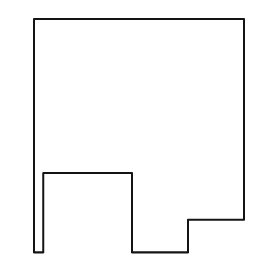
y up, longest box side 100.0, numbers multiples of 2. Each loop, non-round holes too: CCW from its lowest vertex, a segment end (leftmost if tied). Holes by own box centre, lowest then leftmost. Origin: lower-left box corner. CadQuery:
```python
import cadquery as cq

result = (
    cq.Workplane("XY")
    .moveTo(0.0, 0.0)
    .lineTo(4.0, 0.0)
    .lineTo(4.0, 34.0)
    .lineTo(42.0, 34.0)
    .lineTo(42.0, 0.0)
    .lineTo(66.0, 0.0)
    .lineTo(66.0, 14.0)
    .lineTo(90.0, 14.0)
    .lineTo(90.0, 100.0)
    .lineTo(0.0, 100.0)
    .close()
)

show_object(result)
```